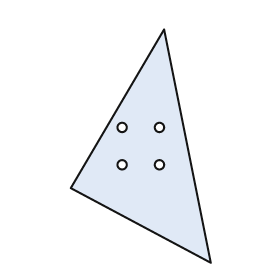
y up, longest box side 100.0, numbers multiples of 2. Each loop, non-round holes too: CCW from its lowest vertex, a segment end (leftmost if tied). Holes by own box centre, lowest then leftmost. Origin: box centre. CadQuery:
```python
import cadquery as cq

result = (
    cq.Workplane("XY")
    .moveTo(30.0, -50.0)
    .lineTo(10.0, 50.0)
    .lineTo(-30.0, -18.0)
    .close()
    .moveTo(-8.0, -8.0)
    .circle(2.0)
    .moveTo(8.0, -8.0)
    .circle(2.0)
    .moveTo(-8.0, 8.0)
    .circle(2.0)
    .moveTo(8.0, 8.0)
    .circle(2.0)
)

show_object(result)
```